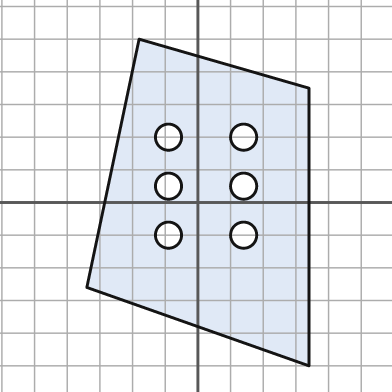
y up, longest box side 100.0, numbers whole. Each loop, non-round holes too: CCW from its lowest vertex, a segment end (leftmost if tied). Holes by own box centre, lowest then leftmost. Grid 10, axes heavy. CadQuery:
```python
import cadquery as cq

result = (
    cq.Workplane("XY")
    .moveTo(34.0, -50.0)
    .lineTo(34.0, 35.0)
    .lineTo(-18.0, 50.0)
    .lineTo(-34.0, -26.0)
    .close()
    .moveTo(-9.0, -10.0)
    .circle(4.0)
    .moveTo(14.0, -10.0)
    .circle(4.0)
    .moveTo(-9.0, 5.0)
    .circle(4.0)
    .moveTo(14.0, 5.0)
    .circle(4.0)
    .moveTo(-9.0, 20.0)
    .circle(4.0)
    .moveTo(14.0, 20.0)
    .circle(4.0)
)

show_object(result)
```